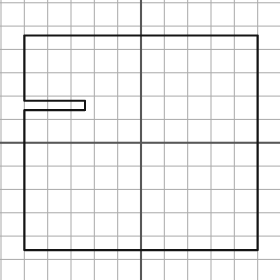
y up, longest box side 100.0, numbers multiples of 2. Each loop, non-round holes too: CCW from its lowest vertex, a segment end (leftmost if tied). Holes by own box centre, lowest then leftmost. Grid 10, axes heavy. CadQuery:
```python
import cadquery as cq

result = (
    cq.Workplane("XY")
    .moveTo(-50.0, -46.0)
    .lineTo(50.0, -46.0)
    .lineTo(50.0, 46.0)
    .lineTo(-50.0, 46.0)
    .lineTo(-50.0, 18.0)
    .lineTo(-24.0, 18.0)
    .lineTo(-24.0, 14.0)
    .lineTo(-50.0, 14.0)
    .close()
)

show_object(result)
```